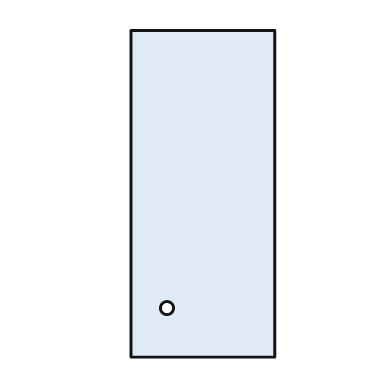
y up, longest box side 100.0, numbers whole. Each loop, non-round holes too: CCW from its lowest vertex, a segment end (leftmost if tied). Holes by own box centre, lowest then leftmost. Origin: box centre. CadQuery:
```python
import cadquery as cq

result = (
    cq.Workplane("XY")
    .moveTo(-22.0, -50.0)
    .lineTo(22.0, -50.0)
    .lineTo(22.0, 50.0)
    .lineTo(-22.0, 50.0)
    .close()
    .moveTo(-11.0, -35.0)
    .circle(2.0)
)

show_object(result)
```